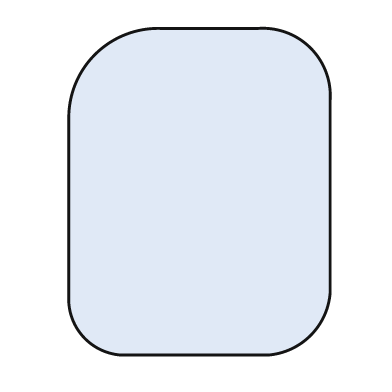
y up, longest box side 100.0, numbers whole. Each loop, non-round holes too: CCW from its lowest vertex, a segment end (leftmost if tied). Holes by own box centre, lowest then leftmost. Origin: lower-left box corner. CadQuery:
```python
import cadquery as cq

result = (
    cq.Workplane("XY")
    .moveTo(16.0, 0.0)
    .lineTo(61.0, 0.0)
    .threePointArc((74.0, 6.0), (80.0, 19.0))
    .lineTo(80.0, 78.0)
    .threePointArc((74.0, 94.0), (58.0, 100.0))
    .lineTo(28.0, 100.0)
    .threePointArc((8.0, 92.0), (0.0, 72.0))
    .lineTo(0.0, 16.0)
    .threePointArc((5.0, 5.0), (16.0, 0.0))
    .close()
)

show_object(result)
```